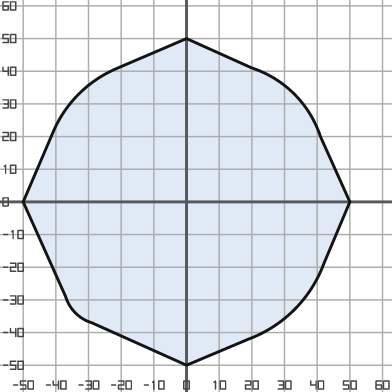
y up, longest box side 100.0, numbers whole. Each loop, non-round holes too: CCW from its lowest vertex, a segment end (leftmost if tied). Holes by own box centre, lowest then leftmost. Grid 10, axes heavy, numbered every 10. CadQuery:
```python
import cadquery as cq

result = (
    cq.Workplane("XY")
    .moveTo(0.0, -50.0)
    .lineTo(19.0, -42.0)
    .threePointArc((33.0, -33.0), (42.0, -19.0))
    .lineTo(50.0, 0.0)
    .lineTo(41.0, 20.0)
    .threePointArc((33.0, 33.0), (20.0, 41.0))
    .lineTo(0.0, 50.0)
    .lineTo(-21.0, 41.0)
    .threePointArc((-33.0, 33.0), (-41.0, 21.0))
    .lineTo(-50.0, 0.0)
    .lineTo(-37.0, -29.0)
    .threePointArc((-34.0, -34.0), (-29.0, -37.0))
    .close()
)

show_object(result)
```